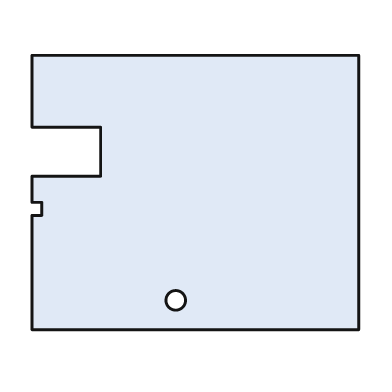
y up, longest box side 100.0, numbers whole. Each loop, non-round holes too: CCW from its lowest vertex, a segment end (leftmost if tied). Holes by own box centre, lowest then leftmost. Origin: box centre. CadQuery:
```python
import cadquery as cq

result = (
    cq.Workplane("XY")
    .moveTo(-50.0, -42.0)
    .lineTo(50.0, -42.0)
    .lineTo(50.0, 42.0)
    .lineTo(-50.0, 42.0)
    .lineTo(-50.0, 20.0)
    .lineTo(-29.0, 20.0)
    .lineTo(-29.0, 5.0)
    .lineTo(-50.0, 5.0)
    .lineTo(-50.0, -3.0)
    .lineTo(-47.0, -3.0)
    .lineTo(-47.0, -7.0)
    .lineTo(-50.0, -7.0)
    .close()
    .moveTo(-6.0, -33.0)
    .circle(3.0)
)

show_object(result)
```